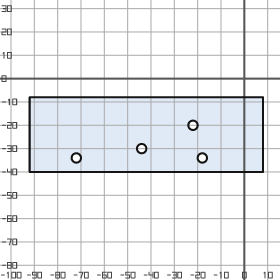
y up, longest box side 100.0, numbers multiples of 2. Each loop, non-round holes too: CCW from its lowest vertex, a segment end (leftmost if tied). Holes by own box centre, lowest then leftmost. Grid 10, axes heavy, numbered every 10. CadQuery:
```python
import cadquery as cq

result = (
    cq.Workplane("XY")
    .moveTo(-92.0, -40.0)
    .lineTo(8.0, -40.0)
    .lineTo(8.0, -8.0)
    .lineTo(-92.0, -8.0)
    .close()
    .moveTo(-72.0, -34.0)
    .circle(2.0)
    .moveTo(-18.0, -34.0)
    .circle(2.0)
    .moveTo(-44.0, -30.0)
    .circle(2.0)
    .moveTo(-22.0, -20.0)
    .circle(2.0)
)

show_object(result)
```